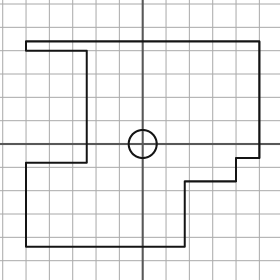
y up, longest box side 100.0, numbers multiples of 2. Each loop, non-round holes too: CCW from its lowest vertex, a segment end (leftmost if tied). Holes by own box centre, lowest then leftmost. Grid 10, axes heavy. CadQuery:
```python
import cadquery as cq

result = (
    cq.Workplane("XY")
    .moveTo(-50.0, -44.0)
    .lineTo(18.0, -44.0)
    .lineTo(18.0, -16.0)
    .lineTo(40.0, -16.0)
    .lineTo(40.0, -6.0)
    .lineTo(50.0, -6.0)
    .lineTo(50.0, 44.0)
    .lineTo(-50.0, 44.0)
    .lineTo(-50.0, 40.0)
    .lineTo(-24.0, 40.0)
    .lineTo(-24.0, -8.0)
    .lineTo(-50.0, -8.0)
    .close()
    .moveTo(0.0, 0.0)
    .circle(6.0)
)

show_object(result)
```